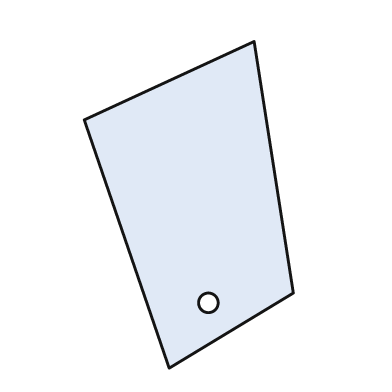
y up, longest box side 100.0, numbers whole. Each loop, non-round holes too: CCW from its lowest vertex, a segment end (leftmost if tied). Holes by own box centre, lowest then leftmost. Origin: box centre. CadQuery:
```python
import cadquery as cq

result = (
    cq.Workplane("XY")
    .moveTo(-6.0, -50.0)
    .lineTo(32.0, -27.0)
    .lineTo(20.0, 50.0)
    .lineTo(-32.0, 26.0)
    .close()
    .moveTo(6.0, -30.0)
    .circle(3.0)
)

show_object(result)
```